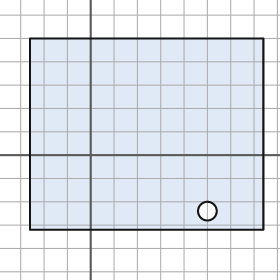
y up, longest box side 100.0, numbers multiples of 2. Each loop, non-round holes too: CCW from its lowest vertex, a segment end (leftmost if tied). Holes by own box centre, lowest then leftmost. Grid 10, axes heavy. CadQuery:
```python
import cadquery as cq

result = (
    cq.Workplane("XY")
    .moveTo(-26.0, -32.0)
    .lineTo(74.0, -32.0)
    .lineTo(74.0, 50.0)
    .lineTo(-26.0, 50.0)
    .close()
    .moveTo(50.0, -24.0)
    .circle(4.0)
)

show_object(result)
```